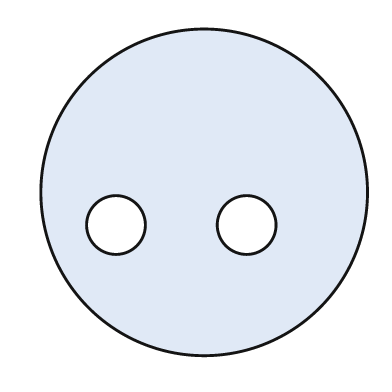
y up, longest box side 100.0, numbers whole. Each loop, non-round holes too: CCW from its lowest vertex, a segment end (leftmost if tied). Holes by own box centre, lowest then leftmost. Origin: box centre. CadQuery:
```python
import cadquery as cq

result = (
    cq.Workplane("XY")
    .moveTo(0.0, 0.0)
    .circle(50.0)
    .moveTo(-27.0, -10.0)
    .circle(9.0)
    .moveTo(13.0, -10.0)
    .circle(9.0)
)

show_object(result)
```